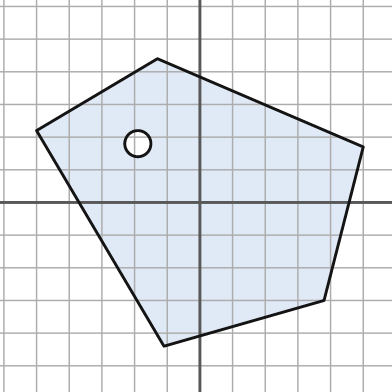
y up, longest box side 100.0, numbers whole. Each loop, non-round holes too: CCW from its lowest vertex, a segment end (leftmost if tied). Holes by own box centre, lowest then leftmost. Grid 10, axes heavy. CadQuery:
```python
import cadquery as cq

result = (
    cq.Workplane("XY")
    .moveTo(-11.0, -44.0)
    .lineTo(38.0, -30.0)
    .lineTo(50.0, 17.0)
    .lineTo(-13.0, 44.0)
    .lineTo(-50.0, 22.0)
    .close()
    .moveTo(-19.0, 18.0)
    .circle(4.0)
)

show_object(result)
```